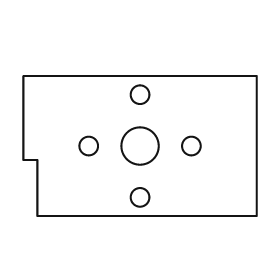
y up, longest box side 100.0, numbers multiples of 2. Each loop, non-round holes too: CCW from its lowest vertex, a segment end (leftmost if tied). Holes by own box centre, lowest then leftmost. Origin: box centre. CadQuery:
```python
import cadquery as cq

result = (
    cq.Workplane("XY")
    .moveTo(-44.0, -30.0)
    .lineTo(50.0, -30.0)
    .lineTo(50.0, 30.0)
    .lineTo(-50.0, 30.0)
    .lineTo(-50.0, -6.0)
    .lineTo(-44.0, -6.0)
    .close()
    .moveTo(0.0, -22.0)
    .circle(4.0)
    .moveTo(-22.0, 0.0)
    .circle(4.0)
    .moveTo(0.0, 0.0)
    .circle(8.0)
    .moveTo(22.0, 0.0)
    .circle(4.0)
    .moveTo(0.0, 22.0)
    .circle(4.0)
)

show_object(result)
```